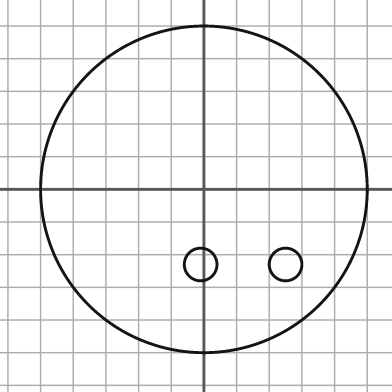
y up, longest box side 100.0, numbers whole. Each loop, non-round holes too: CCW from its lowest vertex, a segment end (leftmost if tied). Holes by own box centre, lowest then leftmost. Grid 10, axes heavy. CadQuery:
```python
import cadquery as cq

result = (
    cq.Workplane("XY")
    .moveTo(0.0, 0.0)
    .circle(50.0)
    .moveTo(-1.0, -23.0)
    .circle(5.0)
    .moveTo(25.0, -23.0)
    .circle(5.0)
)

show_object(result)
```